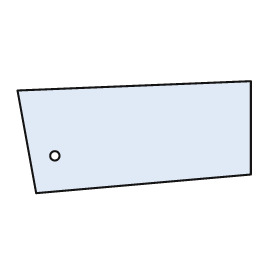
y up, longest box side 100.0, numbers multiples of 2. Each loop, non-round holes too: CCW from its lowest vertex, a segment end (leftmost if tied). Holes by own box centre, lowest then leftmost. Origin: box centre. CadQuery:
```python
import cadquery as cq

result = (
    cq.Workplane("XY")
    .moveTo(-42.0, -24.0)
    .lineTo(50.0, -16.0)
    .lineTo(50.0, 24.0)
    .lineTo(-50.0, 20.0)
    .close()
    .moveTo(-34.0, -8.0)
    .circle(2.0)
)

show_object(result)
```